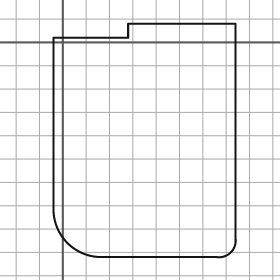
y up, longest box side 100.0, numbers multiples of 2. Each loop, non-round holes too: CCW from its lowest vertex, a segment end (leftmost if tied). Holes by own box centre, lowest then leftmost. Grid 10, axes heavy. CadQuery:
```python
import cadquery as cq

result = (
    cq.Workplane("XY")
    .moveTo(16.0, -92.0)
    .lineTo(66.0, -92.0)
    .threePointArc((72.0, -90.0), (74.0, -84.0))
    .lineTo(74.0, 8.0)
    .lineTo(28.0, 8.0)
    .lineTo(28.0, 2.0)
    .lineTo(-4.0, 2.0)
    .lineTo(-4.0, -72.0)
    .threePointArc((2.0, -86.0), (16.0, -92.0))
    .close()
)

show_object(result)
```